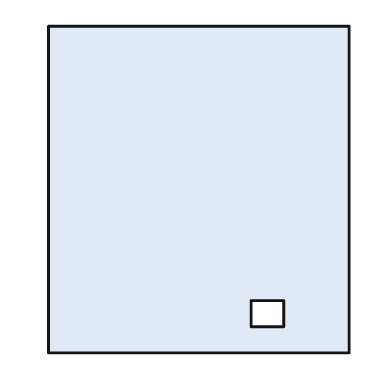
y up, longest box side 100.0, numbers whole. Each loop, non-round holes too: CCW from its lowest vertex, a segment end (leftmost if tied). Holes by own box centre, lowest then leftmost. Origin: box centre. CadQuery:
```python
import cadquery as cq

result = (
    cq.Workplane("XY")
    .moveTo(-46.0, -50.0)
    .lineTo(46.0, -50.0)
    .lineTo(46.0, 50.0)
    .lineTo(-46.0, 50.0)
    .close()
    .moveTo(16.0, -42.0)
    .lineTo(26.0, -42.0)
    .lineTo(26.0, -34.0)
    .lineTo(16.0, -34.0)
    .close()
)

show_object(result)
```